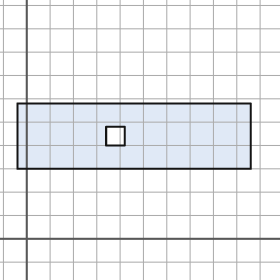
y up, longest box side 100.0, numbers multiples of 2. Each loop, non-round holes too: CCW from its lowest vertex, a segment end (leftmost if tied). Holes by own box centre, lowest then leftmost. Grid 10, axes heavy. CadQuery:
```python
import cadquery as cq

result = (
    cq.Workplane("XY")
    .moveTo(-4.0, 30.0)
    .lineTo(96.0, 30.0)
    .lineTo(96.0, 58.0)
    .lineTo(-4.0, 58.0)
    .close()
    .moveTo(34.0, 40.0)
    .lineTo(42.0, 40.0)
    .lineTo(42.0, 48.0)
    .lineTo(34.0, 48.0)
    .close()
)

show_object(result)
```